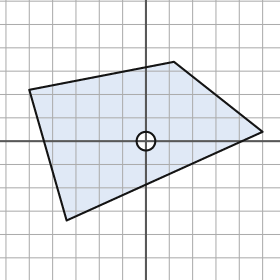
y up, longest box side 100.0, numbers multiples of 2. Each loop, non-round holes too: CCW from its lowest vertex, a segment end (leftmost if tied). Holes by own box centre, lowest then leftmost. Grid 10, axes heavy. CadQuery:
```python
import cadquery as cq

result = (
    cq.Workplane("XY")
    .moveTo(-34.0, -34.0)
    .lineTo(50.0, 4.0)
    .lineTo(12.0, 34.0)
    .lineTo(-50.0, 22.0)
    .close()
    .moveTo(0.0, 0.0)
    .circle(4.0)
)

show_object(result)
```